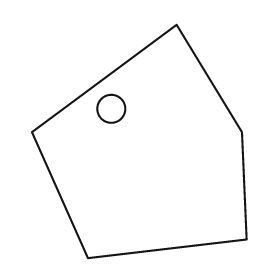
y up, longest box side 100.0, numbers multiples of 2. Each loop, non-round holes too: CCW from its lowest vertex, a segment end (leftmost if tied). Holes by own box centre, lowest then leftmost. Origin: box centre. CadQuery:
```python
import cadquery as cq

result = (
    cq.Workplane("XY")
    .moveTo(-22.0, -50.0)
    .lineTo(46.0, -42.0)
    .lineTo(44.0, 4.0)
    .lineTo(16.0, 50.0)
    .lineTo(-46.0, 4.0)
    .close()
    .moveTo(-12.0, 14.0)
    .circle(6.0)
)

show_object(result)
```